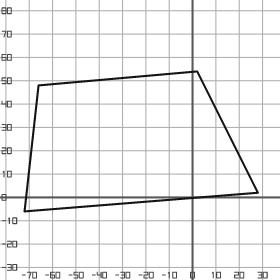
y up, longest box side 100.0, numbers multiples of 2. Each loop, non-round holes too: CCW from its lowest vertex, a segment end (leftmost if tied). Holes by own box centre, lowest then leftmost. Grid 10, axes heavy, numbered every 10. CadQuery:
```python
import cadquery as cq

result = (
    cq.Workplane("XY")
    .moveTo(-72.0, -6.0)
    .lineTo(28.0, 2.0)
    .lineTo(2.0, 54.0)
    .lineTo(-66.0, 48.0)
    .close()
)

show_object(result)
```